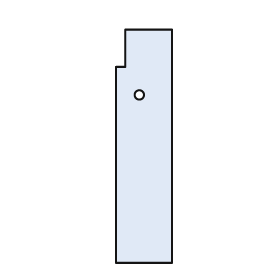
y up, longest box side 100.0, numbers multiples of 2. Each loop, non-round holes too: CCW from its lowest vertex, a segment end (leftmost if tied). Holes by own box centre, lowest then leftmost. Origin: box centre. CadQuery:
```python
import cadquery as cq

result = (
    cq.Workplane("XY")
    .moveTo(-12.0, -50.0)
    .lineTo(12.0, -50.0)
    .lineTo(12.0, 50.0)
    .lineTo(-8.0, 50.0)
    .lineTo(-8.0, 34.0)
    .lineTo(-12.0, 34.0)
    .close()
    .moveTo(-2.0, 22.0)
    .circle(2.0)
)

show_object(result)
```